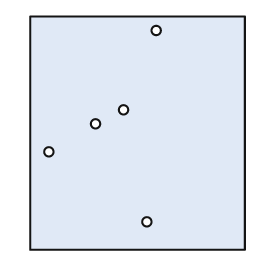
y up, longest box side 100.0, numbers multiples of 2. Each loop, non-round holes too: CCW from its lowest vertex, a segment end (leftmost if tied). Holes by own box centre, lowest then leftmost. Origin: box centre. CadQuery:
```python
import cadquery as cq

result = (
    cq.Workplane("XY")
    .moveTo(-46.0, -50.0)
    .lineTo(46.0, -50.0)
    .lineTo(46.0, 50.0)
    .lineTo(-46.0, 50.0)
    .close()
    .moveTo(4.0, -38.0)
    .circle(2.0)
    .moveTo(-38.0, -8.0)
    .circle(2.0)
    .moveTo(-18.0, 4.0)
    .circle(2.0)
    .moveTo(-6.0, 10.0)
    .circle(2.0)
    .moveTo(8.0, 44.0)
    .circle(2.0)
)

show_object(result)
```